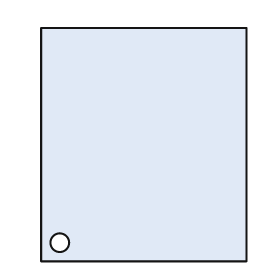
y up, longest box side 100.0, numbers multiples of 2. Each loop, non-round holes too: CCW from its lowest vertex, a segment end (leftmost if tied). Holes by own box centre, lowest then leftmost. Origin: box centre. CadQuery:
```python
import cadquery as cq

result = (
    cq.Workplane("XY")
    .moveTo(-44.0, -50.0)
    .lineTo(44.0, -50.0)
    .lineTo(44.0, 50.0)
    .lineTo(-44.0, 50.0)
    .close()
    .moveTo(-36.0, -42.0)
    .circle(4.0)
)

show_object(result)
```